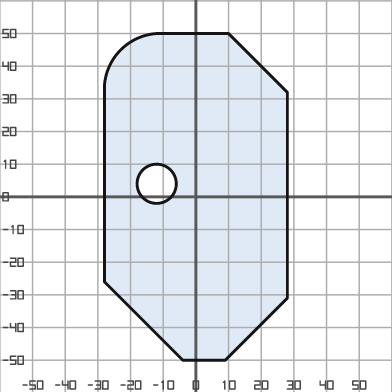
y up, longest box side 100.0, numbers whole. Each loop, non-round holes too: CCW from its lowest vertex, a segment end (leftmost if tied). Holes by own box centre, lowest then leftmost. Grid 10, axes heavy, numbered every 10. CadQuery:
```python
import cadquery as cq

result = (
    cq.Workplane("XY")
    .moveTo(-4.0, -50.0)
    .lineTo(9.0, -50.0)
    .lineTo(28.0, -31.0)
    .lineTo(28.0, 32.0)
    .lineTo(10.0, 50.0)
    .lineTo(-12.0, 50.0)
    .threePointArc((-23.0, 45.0), (-28.0, 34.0))
    .lineTo(-28.0, -26.0)
    .close()
    .moveTo(-12.0, 4.0)
    .circle(6.0)
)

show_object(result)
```